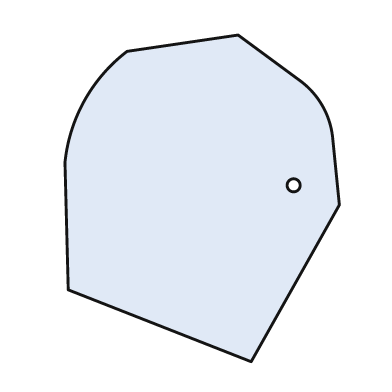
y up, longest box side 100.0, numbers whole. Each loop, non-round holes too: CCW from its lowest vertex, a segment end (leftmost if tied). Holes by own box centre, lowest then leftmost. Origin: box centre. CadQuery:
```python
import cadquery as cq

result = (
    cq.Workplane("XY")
    .moveTo(15.0, -50.0)
    .lineTo(42.0, -2.0)
    .lineTo(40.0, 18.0)
    .threePointArc((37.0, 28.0), (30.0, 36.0))
    .lineTo(11.0, 50.0)
    .lineTo(-23.0, 45.0)
    .threePointArc((-36.0, 30.0), (-42.0, 11.0))
    .lineTo(-41.0, -28.0)
    .close()
    .moveTo(28.0, 4.0)
    .circle(2.0)
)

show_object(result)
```